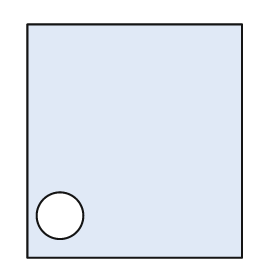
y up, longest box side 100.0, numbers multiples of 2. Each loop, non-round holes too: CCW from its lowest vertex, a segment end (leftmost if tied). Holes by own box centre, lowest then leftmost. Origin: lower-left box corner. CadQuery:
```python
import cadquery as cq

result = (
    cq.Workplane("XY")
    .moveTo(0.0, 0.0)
    .lineTo(92.0, 0.0)
    .lineTo(92.0, 100.0)
    .lineTo(0.0, 100.0)
    .close()
    .moveTo(14.0, 18.0)
    .circle(10.0)
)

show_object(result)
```